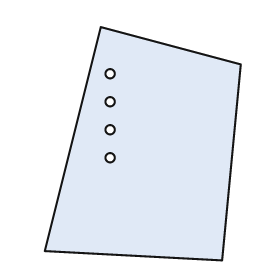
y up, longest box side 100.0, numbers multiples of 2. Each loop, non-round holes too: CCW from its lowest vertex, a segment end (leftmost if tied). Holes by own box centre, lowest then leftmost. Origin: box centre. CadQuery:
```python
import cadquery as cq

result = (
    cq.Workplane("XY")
    .moveTo(34.0, -50.0)
    .lineTo(42.0, 34.0)
    .lineTo(-18.0, 50.0)
    .lineTo(-42.0, -46.0)
    .close()
    .moveTo(-14.0, -6.0)
    .circle(2.0)
    .moveTo(-14.0, 6.0)
    .circle(2.0)
    .moveTo(-14.0, 18.0)
    .circle(2.0)
    .moveTo(-14.0, 30.0)
    .circle(2.0)
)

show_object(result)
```